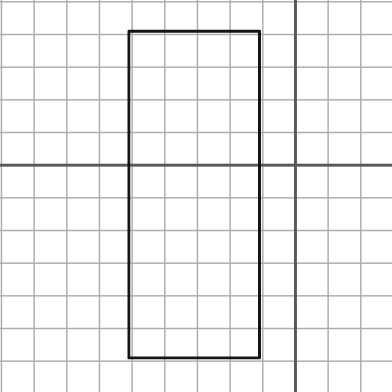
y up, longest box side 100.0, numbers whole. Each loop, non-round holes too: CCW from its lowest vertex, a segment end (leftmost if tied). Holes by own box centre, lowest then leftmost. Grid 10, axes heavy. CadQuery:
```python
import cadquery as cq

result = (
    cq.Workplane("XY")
    .moveTo(-51.0, -59.0)
    .lineTo(-11.0, -59.0)
    .lineTo(-11.0, 41.0)
    .lineTo(-51.0, 41.0)
    .close()
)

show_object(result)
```